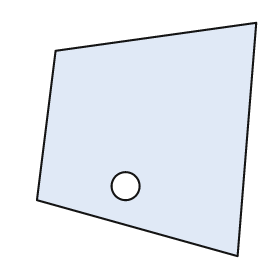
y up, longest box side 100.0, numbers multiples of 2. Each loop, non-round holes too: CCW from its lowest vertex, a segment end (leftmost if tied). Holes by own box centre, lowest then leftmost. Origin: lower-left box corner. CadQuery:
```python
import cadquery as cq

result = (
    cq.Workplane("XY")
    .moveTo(86.0, 0.0)
    .lineTo(94.0, 100.0)
    .lineTo(8.0, 88.0)
    .lineTo(0.0, 24.0)
    .close()
    .moveTo(38.0, 30.0)
    .circle(6.0)
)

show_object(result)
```